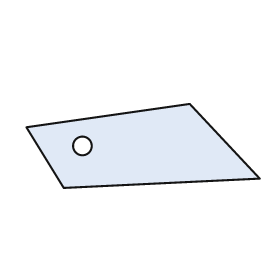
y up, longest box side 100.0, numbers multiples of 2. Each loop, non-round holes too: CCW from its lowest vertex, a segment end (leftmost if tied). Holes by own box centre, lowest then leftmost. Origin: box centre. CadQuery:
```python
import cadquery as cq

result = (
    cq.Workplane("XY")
    .moveTo(-34.0, -18.0)
    .lineTo(50.0, -14.0)
    .lineTo(20.0, 18.0)
    .lineTo(-50.0, 8.0)
    .close()
    .moveTo(-26.0, 0.0)
    .circle(4.0)
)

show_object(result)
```